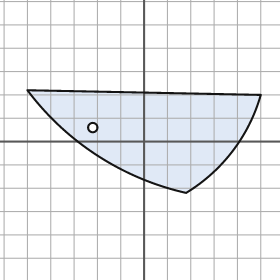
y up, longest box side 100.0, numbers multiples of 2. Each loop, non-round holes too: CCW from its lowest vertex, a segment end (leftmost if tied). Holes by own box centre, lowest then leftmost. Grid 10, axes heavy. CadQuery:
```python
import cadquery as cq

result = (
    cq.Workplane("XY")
    .moveTo(18.0, -22.0)
    .threePointArc((38.0, -4.0), (50.0, 20.0))
    .lineTo(-50.0, 22.0)
    .threePointArc((-20.0, -6.0), (18.0, -22.0))
    .close()
    .moveTo(-22.0, 6.0)
    .circle(2.0)
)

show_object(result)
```